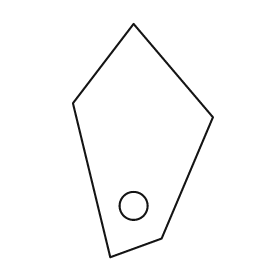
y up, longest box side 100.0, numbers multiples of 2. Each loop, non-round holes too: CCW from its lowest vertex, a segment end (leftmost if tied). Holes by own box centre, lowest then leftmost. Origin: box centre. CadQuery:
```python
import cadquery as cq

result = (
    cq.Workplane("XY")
    .moveTo(-14.0, -50.0)
    .lineTo(8.0, -42.0)
    .lineTo(30.0, 10.0)
    .lineTo(-4.0, 50.0)
    .lineTo(-30.0, 16.0)
    .close()
    .moveTo(-4.0, -28.0)
    .circle(6.0)
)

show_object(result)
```